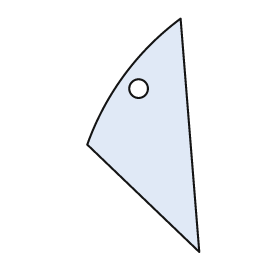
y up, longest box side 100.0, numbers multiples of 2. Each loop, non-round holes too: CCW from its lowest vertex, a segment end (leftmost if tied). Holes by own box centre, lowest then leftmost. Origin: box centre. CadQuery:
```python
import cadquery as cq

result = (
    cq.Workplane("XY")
    .moveTo(24.0, -50.0)
    .lineTo(16.0, 50.0)
    .threePointArc((-8.0, 26.0), (-24.0, -4.0))
    .close()
    .moveTo(-2.0, 20.0)
    .circle(4.0)
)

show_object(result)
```